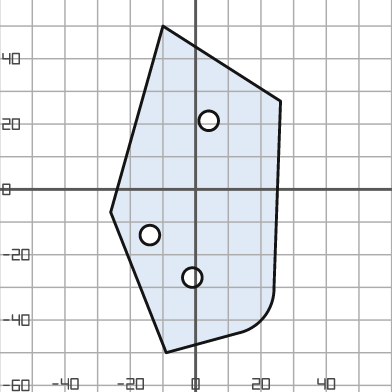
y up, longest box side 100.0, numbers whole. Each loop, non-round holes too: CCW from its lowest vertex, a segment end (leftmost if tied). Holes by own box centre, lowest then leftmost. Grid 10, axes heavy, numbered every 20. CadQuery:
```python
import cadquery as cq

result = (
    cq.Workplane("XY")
    .moveTo(-9.0, -50.0)
    .lineTo(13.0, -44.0)
    .threePointArc((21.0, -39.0), (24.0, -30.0))
    .lineTo(26.0, 27.0)
    .lineTo(-10.0, 50.0)
    .lineTo(-26.0, -7.0)
    .close()
    .moveTo(-1.0, -27.0)
    .circle(3.0)
    .moveTo(-14.0, -14.0)
    .circle(3.0)
    .moveTo(4.0, 21.0)
    .circle(3.0)
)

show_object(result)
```